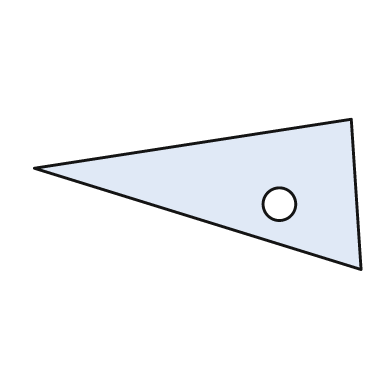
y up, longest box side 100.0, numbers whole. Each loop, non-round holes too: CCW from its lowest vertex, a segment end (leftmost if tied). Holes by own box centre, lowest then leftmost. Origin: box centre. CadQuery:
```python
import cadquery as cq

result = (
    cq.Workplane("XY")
    .moveTo(50.0, -23.0)
    .lineTo(47.0, 23.0)
    .lineTo(-50.0, 8.0)
    .close()
    .moveTo(25.0, -3.0)
    .circle(5.0)
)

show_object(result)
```